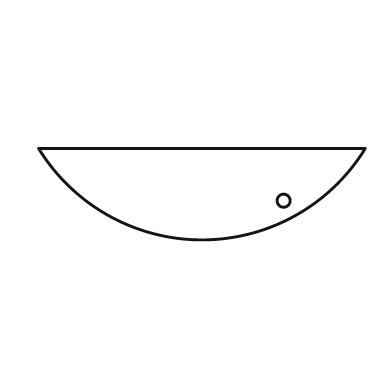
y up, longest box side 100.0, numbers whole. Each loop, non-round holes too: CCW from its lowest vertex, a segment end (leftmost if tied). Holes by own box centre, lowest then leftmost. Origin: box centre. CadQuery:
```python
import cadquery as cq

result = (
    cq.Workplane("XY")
    .moveTo(-50.0, 14.0)
    .threePointArc((0.0, -14.0), (50.0, 14.0))
    .close()
    .moveTo(25.0, -2.0)
    .circle(2.0)
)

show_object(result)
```